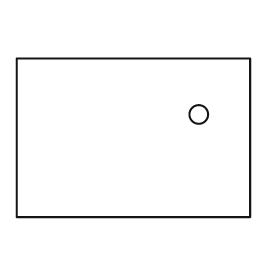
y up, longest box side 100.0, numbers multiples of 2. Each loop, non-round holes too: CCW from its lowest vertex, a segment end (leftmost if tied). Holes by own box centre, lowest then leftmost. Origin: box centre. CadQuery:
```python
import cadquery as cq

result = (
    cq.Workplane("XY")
    .moveTo(-50.0, -34.0)
    .lineTo(50.0, -34.0)
    .lineTo(50.0, 34.0)
    .lineTo(-50.0, 34.0)
    .close()
    .moveTo(28.0, 10.0)
    .circle(4.0)
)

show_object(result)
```